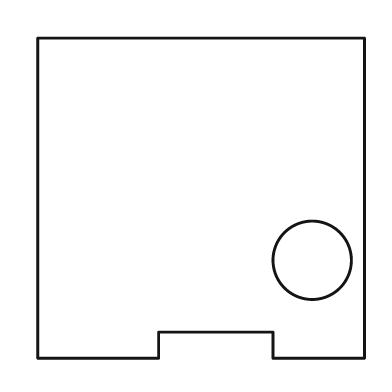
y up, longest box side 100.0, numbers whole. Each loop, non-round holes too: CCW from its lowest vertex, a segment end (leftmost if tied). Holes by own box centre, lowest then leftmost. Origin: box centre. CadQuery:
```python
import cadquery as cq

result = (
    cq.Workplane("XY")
    .moveTo(-50.0, -49.0)
    .lineTo(-13.0, -49.0)
    .lineTo(-13.0, -41.0)
    .lineTo(22.0, -41.0)
    .lineTo(22.0, -49.0)
    .lineTo(50.0, -49.0)
    .lineTo(50.0, 49.0)
    .lineTo(-50.0, 49.0)
    .close()
    .moveTo(34.0, -19.0)
    .circle(12.0)
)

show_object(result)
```